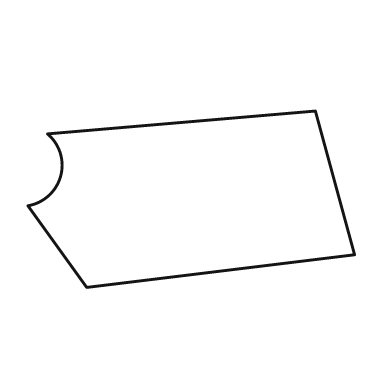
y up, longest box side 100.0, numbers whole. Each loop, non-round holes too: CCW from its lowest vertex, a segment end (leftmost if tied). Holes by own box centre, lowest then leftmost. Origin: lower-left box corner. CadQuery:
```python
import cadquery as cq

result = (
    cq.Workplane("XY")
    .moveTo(18.0, 0.0)
    .lineTo(100.0, 10.0)
    .lineTo(88.0, 54.0)
    .lineTo(6.0, 47.0)
    .threePointArc((10.0, 34.0), (0.0, 25.0))
    .close()
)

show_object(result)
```